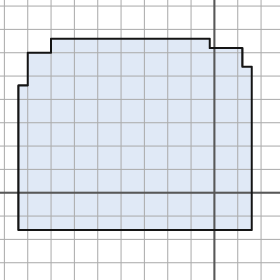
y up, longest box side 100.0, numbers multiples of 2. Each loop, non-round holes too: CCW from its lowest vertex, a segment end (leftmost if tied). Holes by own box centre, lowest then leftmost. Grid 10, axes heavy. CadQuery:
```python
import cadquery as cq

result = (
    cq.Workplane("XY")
    .moveTo(-84.0, -16.0)
    .lineTo(16.0, -16.0)
    .lineTo(16.0, 54.0)
    .lineTo(12.0, 54.0)
    .lineTo(12.0, 62.0)
    .lineTo(-2.0, 62.0)
    .lineTo(-2.0, 66.0)
    .lineTo(-70.0, 66.0)
    .lineTo(-70.0, 60.0)
    .lineTo(-80.0, 60.0)
    .lineTo(-80.0, 46.0)
    .lineTo(-84.0, 46.0)
    .close()
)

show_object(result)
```